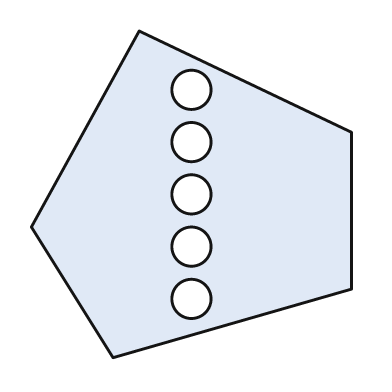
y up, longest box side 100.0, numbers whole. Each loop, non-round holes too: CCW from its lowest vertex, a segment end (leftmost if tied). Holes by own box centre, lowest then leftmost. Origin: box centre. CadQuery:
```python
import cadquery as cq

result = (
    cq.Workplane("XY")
    .moveTo(-24.0, -50.0)
    .lineTo(49.0, -29.0)
    .lineTo(49.0, 19.0)
    .lineTo(-16.0, 50.0)
    .lineTo(-49.0, -10.0)
    .close()
    .moveTo(0.0, -32.0)
    .circle(6.0)
    .moveTo(0.0, -16.0)
    .circle(6.0)
    .moveTo(0.0, 0.0)
    .circle(6.0)
    .moveTo(0.0, 16.0)
    .circle(6.0)
    .moveTo(0.0, 32.0)
    .circle(6.0)
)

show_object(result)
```